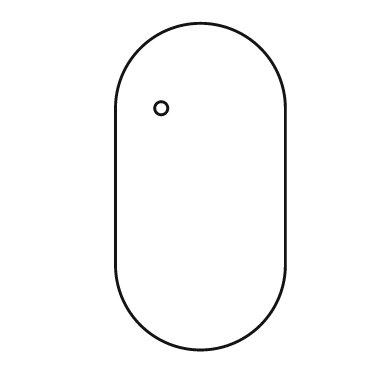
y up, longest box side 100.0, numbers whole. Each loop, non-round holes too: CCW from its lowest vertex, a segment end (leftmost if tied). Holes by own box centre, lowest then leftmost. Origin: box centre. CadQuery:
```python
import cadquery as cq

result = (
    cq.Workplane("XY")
    .moveTo(-26.0, -24.0)
    .threePointArc((0.0, -50.0), (26.0, -24.0))
    .lineTo(26.0, 24.0)
    .threePointArc((0.0, 50.0), (-26.0, 24.0))
    .close()
    .moveTo(-12.0, 24.0)
    .circle(2.0)
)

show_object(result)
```